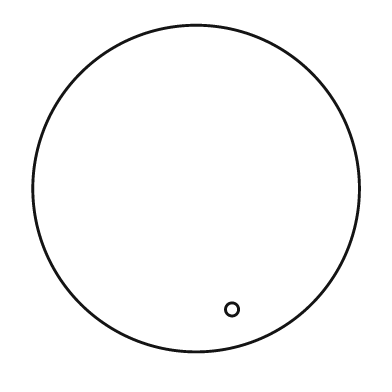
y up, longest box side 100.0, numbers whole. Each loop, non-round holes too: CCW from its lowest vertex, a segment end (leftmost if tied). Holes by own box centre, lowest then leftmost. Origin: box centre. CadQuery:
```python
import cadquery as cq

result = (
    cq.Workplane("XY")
    .moveTo(0.0, 0.0)
    .circle(50.0)
    .moveTo(11.0, -37.0)
    .circle(2.0)
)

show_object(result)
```